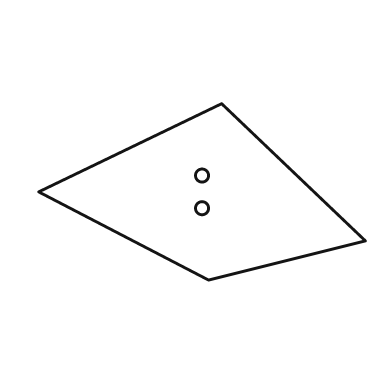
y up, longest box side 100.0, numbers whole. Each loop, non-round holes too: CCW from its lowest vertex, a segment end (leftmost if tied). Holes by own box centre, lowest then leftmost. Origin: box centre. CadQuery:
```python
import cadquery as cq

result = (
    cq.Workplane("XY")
    .moveTo(2.0, -27.0)
    .lineTo(50.0, -15.0)
    .lineTo(6.0, 27.0)
    .lineTo(-50.0, 0.0)
    .close()
    .moveTo(0.0, -5.0)
    .circle(2.0)
    .moveTo(0.0, 5.0)
    .circle(2.0)
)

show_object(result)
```